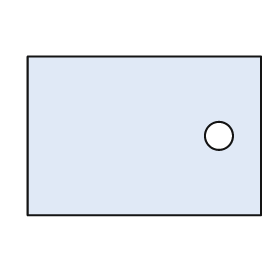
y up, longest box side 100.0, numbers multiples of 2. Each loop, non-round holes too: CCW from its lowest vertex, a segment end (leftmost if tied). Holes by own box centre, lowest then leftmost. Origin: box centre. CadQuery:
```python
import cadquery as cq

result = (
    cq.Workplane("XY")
    .moveTo(-50.0, -34.0)
    .lineTo(50.0, -34.0)
    .lineTo(50.0, 34.0)
    .lineTo(-50.0, 34.0)
    .close()
    .moveTo(32.0, 0.0)
    .circle(6.0)
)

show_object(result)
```